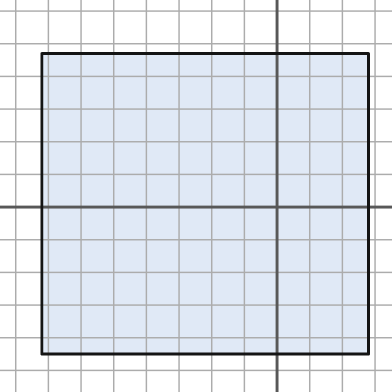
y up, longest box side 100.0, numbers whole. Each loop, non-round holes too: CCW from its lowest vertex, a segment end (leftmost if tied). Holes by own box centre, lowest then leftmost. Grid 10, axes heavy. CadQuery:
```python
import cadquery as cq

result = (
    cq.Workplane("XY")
    .moveTo(-72.0, -45.0)
    .lineTo(28.0, -45.0)
    .lineTo(28.0, 47.0)
    .lineTo(-72.0, 47.0)
    .close()
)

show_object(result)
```